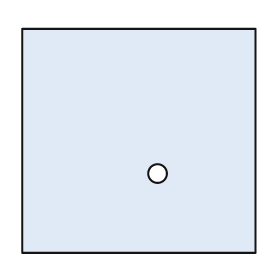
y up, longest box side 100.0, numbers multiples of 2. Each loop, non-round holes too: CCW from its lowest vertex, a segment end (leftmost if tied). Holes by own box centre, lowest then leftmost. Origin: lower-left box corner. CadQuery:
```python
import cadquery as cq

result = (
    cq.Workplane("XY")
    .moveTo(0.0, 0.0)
    .lineTo(100.0, 0.0)
    .lineTo(100.0, 96.0)
    .lineTo(0.0, 96.0)
    .close()
    .moveTo(58.0, 34.0)
    .circle(4.0)
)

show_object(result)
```